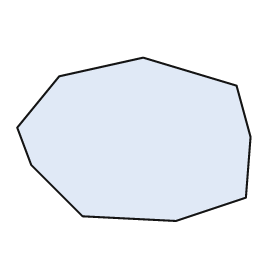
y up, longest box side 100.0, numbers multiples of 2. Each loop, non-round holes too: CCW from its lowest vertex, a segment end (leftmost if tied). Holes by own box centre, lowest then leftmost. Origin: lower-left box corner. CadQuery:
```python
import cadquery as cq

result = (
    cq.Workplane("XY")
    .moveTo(68.0, 0.0)
    .lineTo(98.0, 10.0)
    .lineTo(100.0, 36.0)
    .lineTo(94.0, 58.0)
    .lineTo(54.0, 70.0)
    .lineTo(18.0, 62.0)
    .lineTo(0.0, 40.0)
    .lineTo(6.0, 24.0)
    .lineTo(28.0, 2.0)
    .close()
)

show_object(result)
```